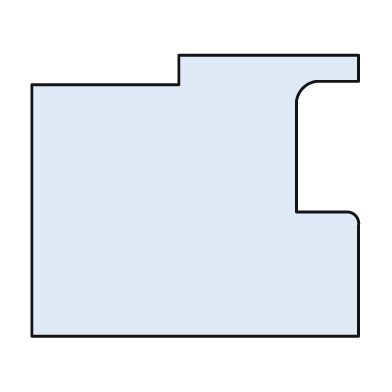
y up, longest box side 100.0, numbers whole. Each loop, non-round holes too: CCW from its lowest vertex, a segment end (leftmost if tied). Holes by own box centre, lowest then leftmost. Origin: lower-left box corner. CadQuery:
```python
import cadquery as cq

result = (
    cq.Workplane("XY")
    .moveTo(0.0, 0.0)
    .lineTo(100.0, 0.0)
    .lineTo(100.0, 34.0)
    .threePointArc((99.0, 37.0), (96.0, 38.0))
    .lineTo(81.0, 38.0)
    .lineTo(81.0, 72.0)
    .threePointArc((83.0, 76.0), (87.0, 78.0))
    .lineTo(100.0, 78.0)
    .lineTo(100.0, 86.0)
    .lineTo(45.0, 86.0)
    .lineTo(45.0, 77.0)
    .lineTo(0.0, 77.0)
    .close()
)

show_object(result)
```